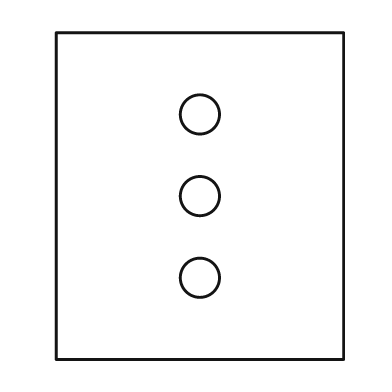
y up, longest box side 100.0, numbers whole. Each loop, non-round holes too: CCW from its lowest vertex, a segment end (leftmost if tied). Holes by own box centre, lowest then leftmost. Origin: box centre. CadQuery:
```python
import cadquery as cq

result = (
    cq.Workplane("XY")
    .moveTo(-44.0, -50.0)
    .lineTo(44.0, -50.0)
    .lineTo(44.0, 50.0)
    .lineTo(-44.0, 50.0)
    .close()
    .moveTo(0.0, -25.0)
    .circle(6.0)
    .moveTo(0.0, 0.0)
    .circle(6.0)
    .moveTo(0.0, 25.0)
    .circle(6.0)
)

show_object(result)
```